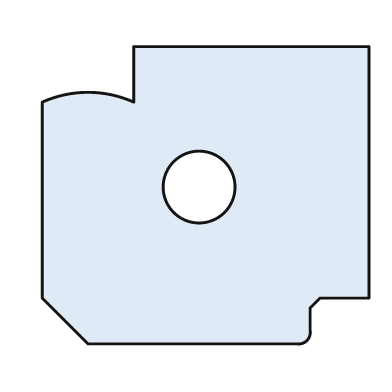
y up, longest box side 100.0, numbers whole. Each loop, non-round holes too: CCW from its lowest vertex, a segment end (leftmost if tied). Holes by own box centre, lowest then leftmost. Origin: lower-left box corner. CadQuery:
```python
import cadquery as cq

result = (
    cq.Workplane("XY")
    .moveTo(14.0, 0.0)
    .lineTo(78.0, 0.0)
    .threePointArc((81.0, 1.0), (82.0, 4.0))
    .lineTo(82.0, 11.0)
    .lineTo(85.0, 14.0)
    .lineTo(100.0, 14.0)
    .lineTo(100.0, 91.0)
    .lineTo(28.0, 91.0)
    .lineTo(28.0, 74.0)
    .threePointArc((14.0, 77.0), (0.0, 74.0))
    .lineTo(0.0, 14.0)
    .close()
    .moveTo(48.0, 48.0)
    .circle(11.0)
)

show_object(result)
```